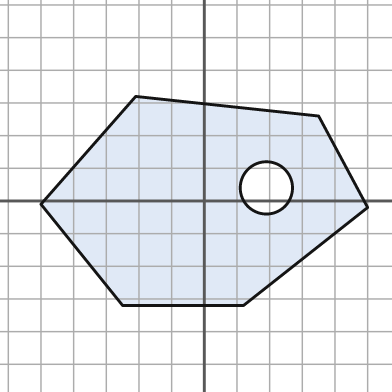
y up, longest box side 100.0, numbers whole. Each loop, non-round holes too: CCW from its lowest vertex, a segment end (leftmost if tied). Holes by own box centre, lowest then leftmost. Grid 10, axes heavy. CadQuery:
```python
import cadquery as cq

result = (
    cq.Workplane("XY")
    .moveTo(-25.0, -32.0)
    .lineTo(12.0, -32.0)
    .lineTo(50.0, -2.0)
    .lineTo(35.0, 26.0)
    .lineTo(-21.0, 32.0)
    .lineTo(-50.0, -1.0)
    .close()
    .moveTo(19.0, 4.0)
    .circle(8.0)
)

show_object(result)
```